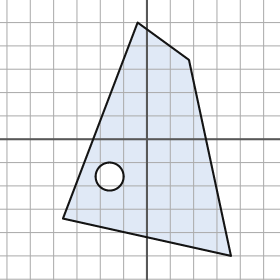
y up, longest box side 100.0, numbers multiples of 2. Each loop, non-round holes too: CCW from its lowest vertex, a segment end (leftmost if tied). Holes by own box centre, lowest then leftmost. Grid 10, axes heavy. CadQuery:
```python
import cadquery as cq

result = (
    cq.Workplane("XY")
    .moveTo(36.0, -50.0)
    .lineTo(18.0, 34.0)
    .lineTo(-4.0, 50.0)
    .lineTo(-36.0, -34.0)
    .close()
    .moveTo(-16.0, -16.0)
    .circle(6.0)
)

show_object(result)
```